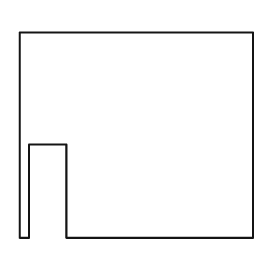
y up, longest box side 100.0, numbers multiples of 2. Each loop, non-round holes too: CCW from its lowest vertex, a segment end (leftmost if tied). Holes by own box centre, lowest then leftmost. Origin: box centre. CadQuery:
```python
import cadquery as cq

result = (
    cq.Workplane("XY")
    .moveTo(-50.0, -44.0)
    .lineTo(-46.0, -44.0)
    .lineTo(-46.0, -4.0)
    .lineTo(-30.0, -4.0)
    .lineTo(-30.0, -44.0)
    .lineTo(50.0, -44.0)
    .lineTo(50.0, 44.0)
    .lineTo(-50.0, 44.0)
    .close()
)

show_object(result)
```